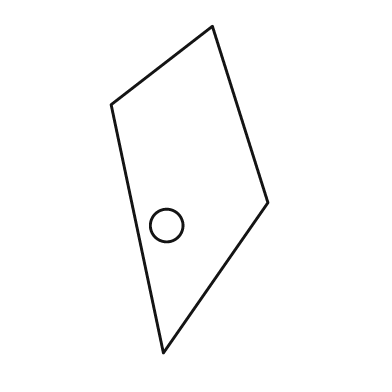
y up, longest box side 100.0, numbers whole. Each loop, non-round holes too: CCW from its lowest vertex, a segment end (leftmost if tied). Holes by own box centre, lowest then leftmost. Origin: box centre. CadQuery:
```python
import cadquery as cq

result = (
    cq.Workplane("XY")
    .moveTo(-8.0, -50.0)
    .lineTo(24.0, -4.0)
    .lineTo(7.0, 50.0)
    .lineTo(-24.0, 26.0)
    .close()
    .moveTo(-7.0, -11.0)
    .circle(5.0)
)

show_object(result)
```